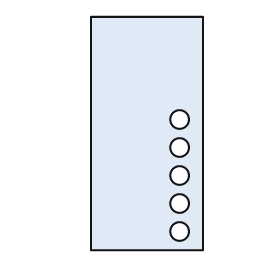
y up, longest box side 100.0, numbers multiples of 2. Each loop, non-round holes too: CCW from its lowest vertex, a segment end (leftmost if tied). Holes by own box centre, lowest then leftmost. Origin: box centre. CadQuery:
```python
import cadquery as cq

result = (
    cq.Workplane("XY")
    .moveTo(-24.0, -50.0)
    .lineTo(24.0, -50.0)
    .lineTo(24.0, 50.0)
    .lineTo(-24.0, 50.0)
    .close()
    .moveTo(14.0, -42.0)
    .circle(4.0)
    .moveTo(14.0, -30.0)
    .circle(4.0)
    .moveTo(14.0, -18.0)
    .circle(4.0)
    .moveTo(14.0, -6.0)
    .circle(4.0)
    .moveTo(14.0, 6.0)
    .circle(4.0)
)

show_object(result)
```